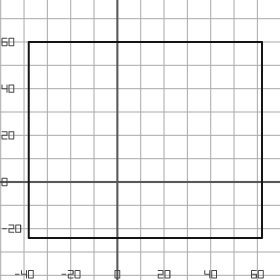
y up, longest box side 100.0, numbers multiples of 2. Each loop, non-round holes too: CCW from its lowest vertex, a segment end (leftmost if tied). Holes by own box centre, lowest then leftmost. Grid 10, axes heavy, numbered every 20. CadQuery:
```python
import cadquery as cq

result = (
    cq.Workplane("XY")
    .moveTo(-38.0, -24.0)
    .lineTo(62.0, -24.0)
    .lineTo(62.0, 60.0)
    .lineTo(-38.0, 60.0)
    .close()
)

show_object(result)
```